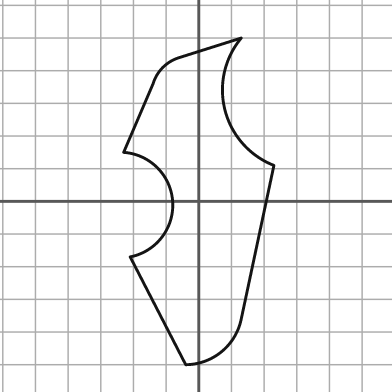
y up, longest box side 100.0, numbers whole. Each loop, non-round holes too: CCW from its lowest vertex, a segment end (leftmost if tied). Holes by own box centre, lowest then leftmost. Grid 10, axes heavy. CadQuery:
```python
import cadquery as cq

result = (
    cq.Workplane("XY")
    .moveTo(-4.0, -50.0)
    .threePointArc((7.0, -46.0), (13.0, -36.0))
    .lineTo(23.0, 11.0)
    .threePointArc((8.0, 28.0), (13.0, 50.0))
    .lineTo(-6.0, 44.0)
    .threePointArc((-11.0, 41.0), (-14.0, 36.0))
    .lineTo(-23.0, 15.0)
    .threePointArc((-8.0, 0.0), (-21.0, -17.0))
    .close()
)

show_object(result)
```